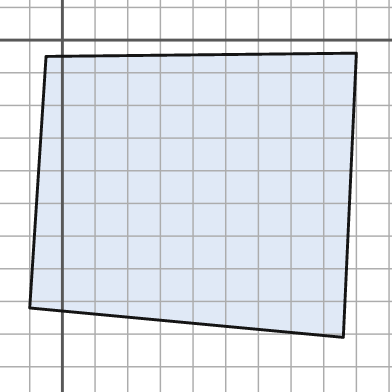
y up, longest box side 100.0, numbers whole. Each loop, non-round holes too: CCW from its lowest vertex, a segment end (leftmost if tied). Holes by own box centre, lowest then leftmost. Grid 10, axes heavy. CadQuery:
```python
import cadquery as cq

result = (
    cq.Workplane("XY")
    .moveTo(86.0, -91.0)
    .lineTo(90.0, -4.0)
    .lineTo(-5.0, -5.0)
    .lineTo(-10.0, -82.0)
    .close()
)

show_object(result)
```